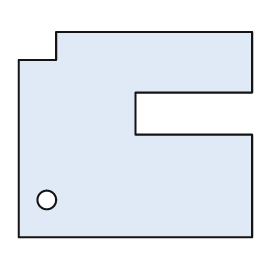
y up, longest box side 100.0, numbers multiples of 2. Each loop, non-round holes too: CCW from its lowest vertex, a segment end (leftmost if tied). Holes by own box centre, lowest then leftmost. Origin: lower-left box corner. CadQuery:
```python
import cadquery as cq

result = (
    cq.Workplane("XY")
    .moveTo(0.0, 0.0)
    .lineTo(100.0, 0.0)
    .lineTo(100.0, 44.0)
    .lineTo(50.0, 44.0)
    .lineTo(50.0, 62.0)
    .lineTo(100.0, 62.0)
    .lineTo(100.0, 88.0)
    .lineTo(16.0, 88.0)
    .lineTo(16.0, 76.0)
    .lineTo(0.0, 76.0)
    .close()
    .moveTo(12.0, 16.0)
    .circle(4.0)
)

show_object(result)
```